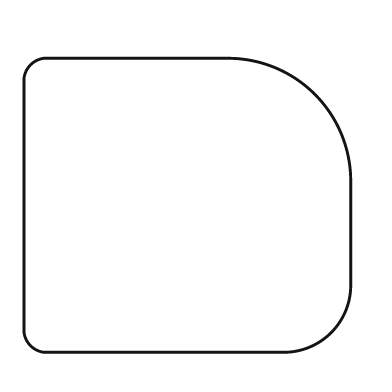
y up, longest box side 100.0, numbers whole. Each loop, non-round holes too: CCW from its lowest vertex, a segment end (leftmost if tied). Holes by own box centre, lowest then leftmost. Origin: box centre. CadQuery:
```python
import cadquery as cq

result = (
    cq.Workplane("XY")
    .moveTo(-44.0, -45.0)
    .lineTo(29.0, -45.0)
    .threePointArc((44.0, -39.0), (50.0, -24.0))
    .lineTo(50.0, 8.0)
    .threePointArc((39.0, 34.0), (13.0, 45.0))
    .lineTo(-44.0, 45.0)
    .threePointArc((-48.0, 43.0), (-50.0, 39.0))
    .lineTo(-50.0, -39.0)
    .threePointArc((-48.0, -43.0), (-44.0, -45.0))
    .close()
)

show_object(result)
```